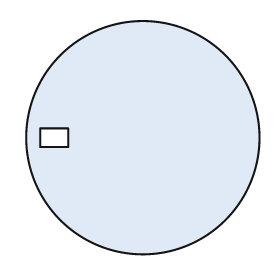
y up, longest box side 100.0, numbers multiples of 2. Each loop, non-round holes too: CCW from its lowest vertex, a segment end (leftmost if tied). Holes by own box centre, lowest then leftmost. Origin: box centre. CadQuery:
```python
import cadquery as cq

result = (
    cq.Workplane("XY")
    .moveTo(0.0, 0.0)
    .circle(50.0)
    .moveTo(-44.0, -4.0)
    .lineTo(-32.0, -4.0)
    .lineTo(-32.0, 4.0)
    .lineTo(-44.0, 4.0)
    .close()
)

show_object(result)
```